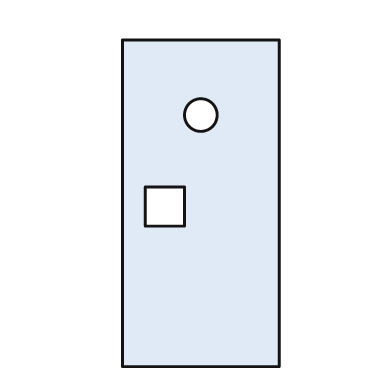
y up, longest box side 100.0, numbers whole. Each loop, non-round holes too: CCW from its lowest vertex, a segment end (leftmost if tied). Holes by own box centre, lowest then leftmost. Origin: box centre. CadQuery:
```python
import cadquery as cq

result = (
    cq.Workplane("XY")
    .moveTo(-24.0, -50.0)
    .lineTo(24.0, -50.0)
    .lineTo(24.0, 50.0)
    .lineTo(-24.0, 50.0)
    .close()
    .moveTo(-17.0, -7.0)
    .lineTo(-5.0, -7.0)
    .lineTo(-5.0, 5.0)
    .lineTo(-17.0, 5.0)
    .close()
    .moveTo(0.0, 27.0)
    .circle(5.0)
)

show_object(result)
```